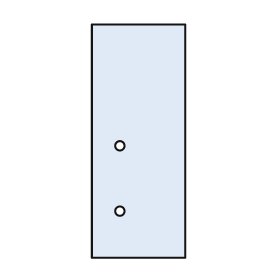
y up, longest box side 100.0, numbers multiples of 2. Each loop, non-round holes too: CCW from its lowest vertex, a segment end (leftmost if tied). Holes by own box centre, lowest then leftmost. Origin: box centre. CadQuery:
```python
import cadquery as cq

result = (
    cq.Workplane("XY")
    .moveTo(-20.0, -50.0)
    .lineTo(20.0, -50.0)
    .lineTo(20.0, 50.0)
    .lineTo(-20.0, 50.0)
    .close()
    .moveTo(-8.0, -30.0)
    .circle(2.0)
    .moveTo(-8.0, -2.0)
    .circle(2.0)
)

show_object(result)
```